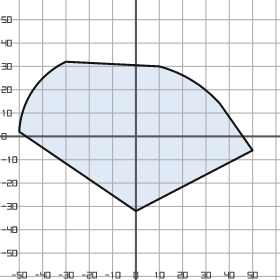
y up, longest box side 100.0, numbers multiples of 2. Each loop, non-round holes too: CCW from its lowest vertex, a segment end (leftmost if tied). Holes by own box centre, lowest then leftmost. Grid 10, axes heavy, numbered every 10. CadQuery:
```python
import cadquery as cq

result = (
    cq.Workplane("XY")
    .moveTo(0.0, -32.0)
    .lineTo(50.0, -6.0)
    .lineTo(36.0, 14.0)
    .threePointArc((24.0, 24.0), (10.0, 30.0))
    .lineTo(-30.0, 32.0)
    .threePointArc((-44.0, 20.0), (-50.0, 2.0))
    .close()
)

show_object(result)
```